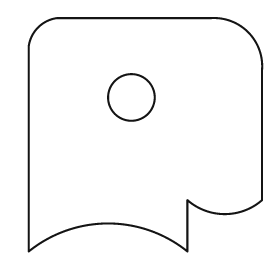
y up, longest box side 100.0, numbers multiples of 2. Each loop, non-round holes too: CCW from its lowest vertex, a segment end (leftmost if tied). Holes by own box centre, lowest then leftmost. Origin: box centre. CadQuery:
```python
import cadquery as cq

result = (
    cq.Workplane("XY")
    .moveTo(-50.0, -50.0)
    .threePointArc((-16.0, -38.0), (18.0, -50.0))
    .lineTo(18.0, -28.0)
    .threePointArc((34.0, -34.0), (50.0, -28.0))
    .lineTo(50.0, 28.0)
    .threePointArc((44.0, 44.0), (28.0, 50.0))
    .lineTo(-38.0, 50.0)
    .threePointArc((-46.0, 46.0), (-50.0, 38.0))
    .close()
    .moveTo(-6.0, 16.0)
    .circle(10.0)
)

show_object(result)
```